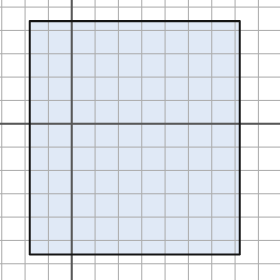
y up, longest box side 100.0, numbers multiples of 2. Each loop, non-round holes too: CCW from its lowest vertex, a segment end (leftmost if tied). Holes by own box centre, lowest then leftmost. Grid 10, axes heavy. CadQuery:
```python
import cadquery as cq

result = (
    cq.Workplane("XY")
    .moveTo(-18.0, -56.0)
    .lineTo(72.0, -56.0)
    .lineTo(72.0, 44.0)
    .lineTo(-18.0, 44.0)
    .close()
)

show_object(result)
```